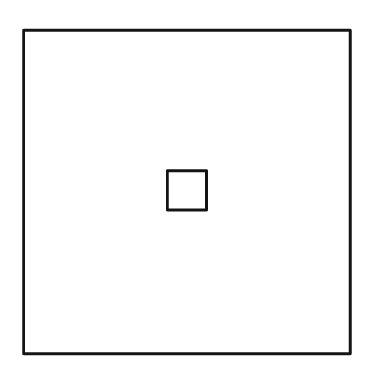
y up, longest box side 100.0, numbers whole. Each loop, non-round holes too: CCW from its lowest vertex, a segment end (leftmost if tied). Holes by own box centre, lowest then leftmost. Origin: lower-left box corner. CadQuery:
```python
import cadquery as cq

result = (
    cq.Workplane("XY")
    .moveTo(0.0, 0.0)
    .lineTo(100.0, 0.0)
    .lineTo(100.0, 99.0)
    .lineTo(0.0, 99.0)
    .close()
    .moveTo(44.0, 44.0)
    .lineTo(56.0, 44.0)
    .lineTo(56.0, 56.0)
    .lineTo(44.0, 56.0)
    .close()
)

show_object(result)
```